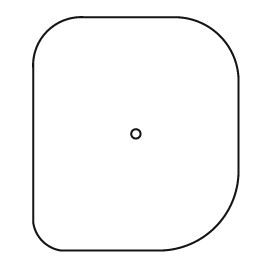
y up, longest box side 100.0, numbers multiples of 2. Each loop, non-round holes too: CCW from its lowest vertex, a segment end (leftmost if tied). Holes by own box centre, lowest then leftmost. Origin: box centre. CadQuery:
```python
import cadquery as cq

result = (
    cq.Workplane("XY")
    .moveTo(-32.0, -50.0)
    .lineTo(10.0, -50.0)
    .threePointArc((34.0, -40.0), (44.0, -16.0))
    .lineTo(44.0, 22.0)
    .threePointArc((36.0, 42.0), (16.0, 50.0))
    .lineTo(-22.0, 50.0)
    .threePointArc((-38.0, 44.0), (-44.0, 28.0))
    .lineTo(-44.0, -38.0)
    .threePointArc((-40.0, -46.0), (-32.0, -50.0))
    .close()
    .moveTo(0.0, 0.0)
    .circle(2.0)
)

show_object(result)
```